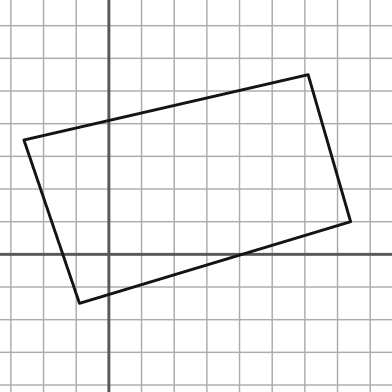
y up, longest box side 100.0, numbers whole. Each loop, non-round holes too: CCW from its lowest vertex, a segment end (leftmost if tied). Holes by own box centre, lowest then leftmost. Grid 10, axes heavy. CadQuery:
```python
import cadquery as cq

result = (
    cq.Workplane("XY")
    .moveTo(-9.0, -15.0)
    .lineTo(74.0, 10.0)
    .lineTo(61.0, 55.0)
    .lineTo(-26.0, 35.0)
    .close()
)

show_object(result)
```